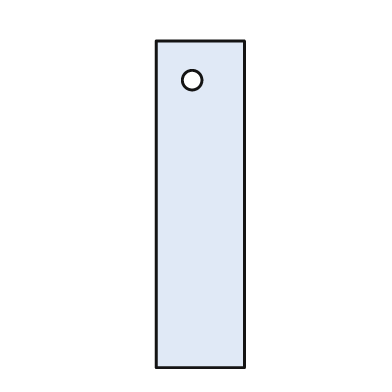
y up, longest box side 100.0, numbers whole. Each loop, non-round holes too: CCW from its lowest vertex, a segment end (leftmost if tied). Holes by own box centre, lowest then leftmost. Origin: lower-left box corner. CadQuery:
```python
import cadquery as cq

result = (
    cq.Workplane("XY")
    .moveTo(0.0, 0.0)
    .lineTo(27.0, 0.0)
    .lineTo(27.0, 100.0)
    .lineTo(0.0, 100.0)
    .close()
    .moveTo(11.0, 88.0)
    .circle(3.0)
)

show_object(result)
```